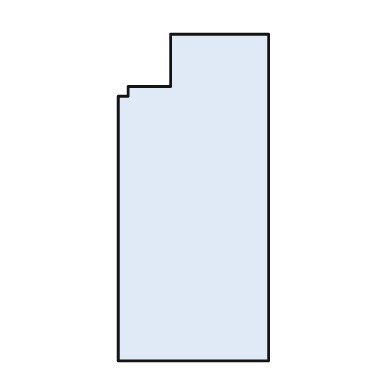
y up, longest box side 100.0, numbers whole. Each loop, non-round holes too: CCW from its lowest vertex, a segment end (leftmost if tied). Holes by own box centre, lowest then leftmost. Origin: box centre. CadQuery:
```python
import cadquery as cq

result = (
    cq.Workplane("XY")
    .moveTo(-23.0, -50.0)
    .lineTo(23.0, -50.0)
    .lineTo(23.0, 50.0)
    .lineTo(-7.0, 50.0)
    .lineTo(-7.0, 34.0)
    .lineTo(-20.0, 34.0)
    .lineTo(-20.0, 31.0)
    .lineTo(-23.0, 31.0)
    .close()
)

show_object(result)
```